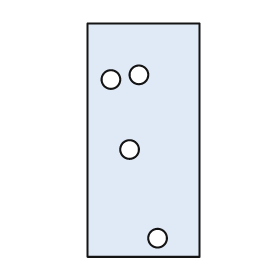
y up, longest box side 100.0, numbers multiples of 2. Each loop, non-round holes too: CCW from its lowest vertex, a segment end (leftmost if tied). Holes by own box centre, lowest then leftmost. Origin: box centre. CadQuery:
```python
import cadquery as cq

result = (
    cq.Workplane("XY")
    .moveTo(-24.0, -50.0)
    .lineTo(24.0, -50.0)
    .lineTo(24.0, 50.0)
    .lineTo(-24.0, 50.0)
    .close()
    .moveTo(6.0, -42.0)
    .circle(4.0)
    .moveTo(-6.0, -4.0)
    .circle(4.0)
    .moveTo(-14.0, 26.0)
    .circle(4.0)
    .moveTo(-2.0, 28.0)
    .circle(4.0)
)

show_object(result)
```